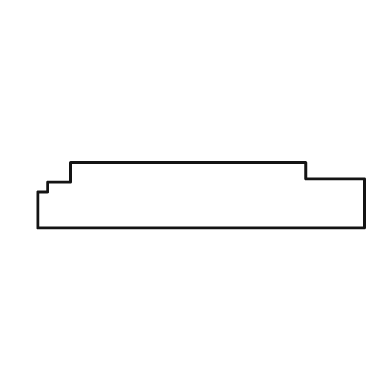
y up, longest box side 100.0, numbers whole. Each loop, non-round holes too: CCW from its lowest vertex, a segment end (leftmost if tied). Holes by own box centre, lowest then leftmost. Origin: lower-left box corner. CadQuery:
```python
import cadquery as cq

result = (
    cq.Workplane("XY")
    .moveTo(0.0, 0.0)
    .lineTo(100.0, 0.0)
    .lineTo(100.0, 15.0)
    .lineTo(82.0, 15.0)
    .lineTo(82.0, 20.0)
    .lineTo(10.0, 20.0)
    .lineTo(10.0, 14.0)
    .lineTo(3.0, 14.0)
    .lineTo(3.0, 11.0)
    .lineTo(0.0, 11.0)
    .close()
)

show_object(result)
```